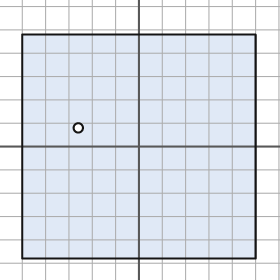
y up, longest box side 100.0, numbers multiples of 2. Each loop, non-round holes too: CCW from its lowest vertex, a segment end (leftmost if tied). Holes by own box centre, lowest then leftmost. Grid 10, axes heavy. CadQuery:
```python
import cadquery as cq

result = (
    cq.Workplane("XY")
    .moveTo(-50.0, -48.0)
    .lineTo(50.0, -48.0)
    .lineTo(50.0, 48.0)
    .lineTo(-50.0, 48.0)
    .close()
    .moveTo(-26.0, 8.0)
    .circle(2.0)
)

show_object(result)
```